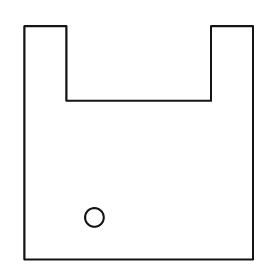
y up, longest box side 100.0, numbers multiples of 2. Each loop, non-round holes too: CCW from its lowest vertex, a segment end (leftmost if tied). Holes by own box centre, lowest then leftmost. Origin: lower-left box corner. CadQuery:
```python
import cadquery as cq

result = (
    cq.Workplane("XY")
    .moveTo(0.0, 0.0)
    .lineTo(98.0, 0.0)
    .lineTo(98.0, 100.0)
    .lineTo(80.0, 100.0)
    .lineTo(80.0, 68.0)
    .lineTo(18.0, 68.0)
    .lineTo(18.0, 100.0)
    .lineTo(0.0, 100.0)
    .close()
    .moveTo(30.0, 18.0)
    .circle(4.0)
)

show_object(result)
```